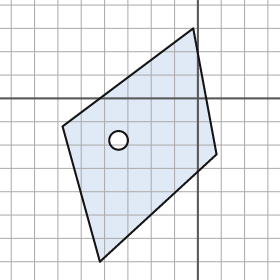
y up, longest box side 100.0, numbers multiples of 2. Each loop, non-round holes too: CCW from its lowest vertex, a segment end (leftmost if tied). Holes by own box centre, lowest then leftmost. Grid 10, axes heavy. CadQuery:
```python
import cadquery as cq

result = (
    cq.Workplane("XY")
    .moveTo(-42.0, -70.0)
    .lineTo(8.0, -24.0)
    .lineTo(-2.0, 30.0)
    .lineTo(-58.0, -12.0)
    .close()
    .moveTo(-34.0, -18.0)
    .circle(4.0)
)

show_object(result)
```